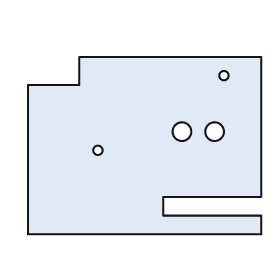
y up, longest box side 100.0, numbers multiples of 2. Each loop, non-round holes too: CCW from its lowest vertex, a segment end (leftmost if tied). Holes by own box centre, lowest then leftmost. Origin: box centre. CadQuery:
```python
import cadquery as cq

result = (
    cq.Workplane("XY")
    .moveTo(-50.0, -38.0)
    .lineTo(50.0, -38.0)
    .lineTo(50.0, -30.0)
    .lineTo(8.0, -30.0)
    .lineTo(8.0, -22.0)
    .lineTo(50.0, -22.0)
    .lineTo(50.0, 38.0)
    .lineTo(-28.0, 38.0)
    .lineTo(-28.0, 26.0)
    .lineTo(-50.0, 26.0)
    .close()
    .moveTo(-20.0, -2.0)
    .circle(2.0)
    .moveTo(16.0, 6.0)
    .circle(4.0)
    .moveTo(30.0, 6.0)
    .circle(4.0)
    .moveTo(34.0, 30.0)
    .circle(2.0)
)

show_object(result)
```